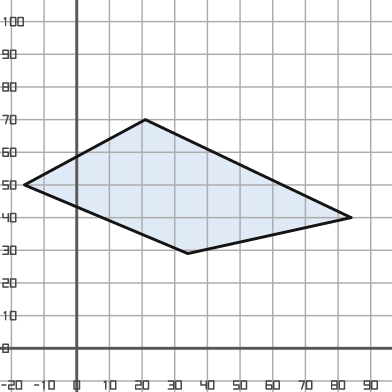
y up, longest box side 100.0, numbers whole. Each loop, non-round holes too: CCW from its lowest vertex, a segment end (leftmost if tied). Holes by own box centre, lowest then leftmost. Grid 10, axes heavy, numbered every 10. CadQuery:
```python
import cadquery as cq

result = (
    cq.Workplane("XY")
    .moveTo(34.0, 29.0)
    .lineTo(84.0, 40.0)
    .lineTo(21.0, 70.0)
    .lineTo(-16.0, 50.0)
    .close()
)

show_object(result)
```